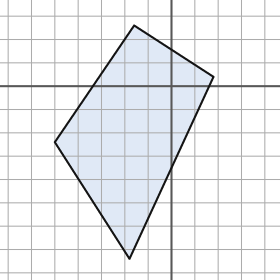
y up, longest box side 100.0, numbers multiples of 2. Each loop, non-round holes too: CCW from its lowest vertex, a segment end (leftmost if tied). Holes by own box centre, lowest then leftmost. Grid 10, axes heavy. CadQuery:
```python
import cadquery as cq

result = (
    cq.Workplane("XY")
    .moveTo(-18.0, -74.0)
    .lineTo(18.0, 4.0)
    .lineTo(-16.0, 26.0)
    .lineTo(-50.0, -24.0)
    .close()
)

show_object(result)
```